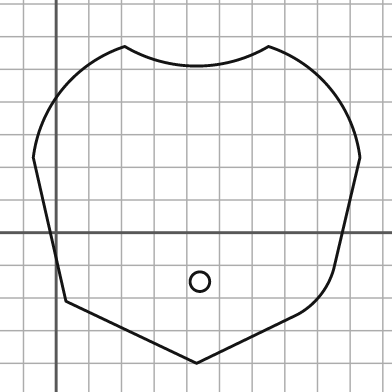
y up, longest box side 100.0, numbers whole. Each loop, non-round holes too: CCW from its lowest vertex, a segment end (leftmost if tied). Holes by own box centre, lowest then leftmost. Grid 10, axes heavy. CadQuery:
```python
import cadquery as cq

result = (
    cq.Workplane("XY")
    .moveTo(43.0, -40.0)
    .lineTo(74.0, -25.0)
    .threePointArc((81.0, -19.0), (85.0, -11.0))
    .lineTo(93.0, 23.0)
    .threePointArc((84.0, 44.0), (65.0, 57.0))
    .threePointArc((43.0, 51.0), (21.0, 57.0))
    .threePointArc((2.0, 44.0), (-7.0, 23.0))
    .lineTo(3.0, -21.0)
    .close()
    .moveTo(44.0, -15.0)
    .circle(3.0)
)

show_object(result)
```